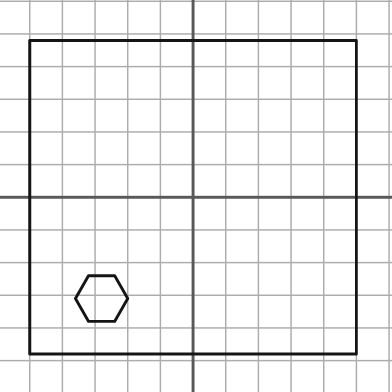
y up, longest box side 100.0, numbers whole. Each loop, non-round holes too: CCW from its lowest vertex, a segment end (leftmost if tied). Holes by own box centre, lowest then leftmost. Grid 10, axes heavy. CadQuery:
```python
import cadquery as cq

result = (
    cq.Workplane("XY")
    .moveTo(-50.0, -48.0)
    .lineTo(50.0, -48.0)
    .lineTo(50.0, 48.0)
    .lineTo(-50.0, 48.0)
    .close()
    .moveTo(-32.0, -38.0)
    .lineTo(-24.0, -38.0)
    .lineTo(-20.0, -31.0)
    .lineTo(-24.0, -24.0)
    .lineTo(-32.0, -24.0)
    .lineTo(-36.0, -31.0)
    .close()
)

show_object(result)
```